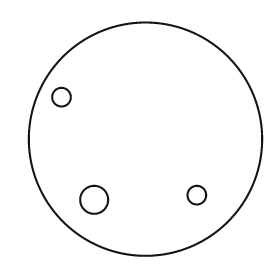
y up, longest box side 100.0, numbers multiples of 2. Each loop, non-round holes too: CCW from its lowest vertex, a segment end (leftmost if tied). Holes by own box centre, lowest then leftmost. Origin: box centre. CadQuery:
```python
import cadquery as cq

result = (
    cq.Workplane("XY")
    .moveTo(0.0, 0.0)
    .circle(50.0)
    .moveTo(-22.0, -26.0)
    .circle(6.0)
    .moveTo(22.0, -24.0)
    .circle(4.0)
    .moveTo(-36.0, 18.0)
    .circle(4.0)
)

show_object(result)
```